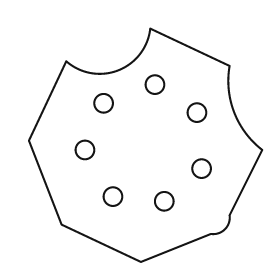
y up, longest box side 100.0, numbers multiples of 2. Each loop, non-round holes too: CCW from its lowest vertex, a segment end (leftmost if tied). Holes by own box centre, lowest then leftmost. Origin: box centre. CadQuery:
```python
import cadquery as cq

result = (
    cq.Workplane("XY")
    .moveTo(-2.0, -50.0)
    .lineTo(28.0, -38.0)
    .threePointArc((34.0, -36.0), (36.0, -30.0))
    .lineTo(50.0, -2.0)
    .threePointArc((38.0, 14.0), (36.0, 34.0))
    .lineTo(2.0, 50.0)
    .threePointArc((-12.0, 32.0), (-34.0, 36.0))
    .lineTo(-50.0, 2.0)
    .lineTo(-36.0, -34.0)
    .close()
    .moveTo(8.0, -24.0)
    .circle(4.0)
    .moveTo(-14.0, -22.0)
    .circle(4.0)
    .moveTo(24.0, -10.0)
    .circle(4.0)
    .moveTo(-26.0, -2.0)
    .circle(4.0)
    .moveTo(22.0, 14.0)
    .circle(4.0)
    .moveTo(-18.0, 18.0)
    .circle(4.0)
    .moveTo(4.0, 26.0)
    .circle(4.0)
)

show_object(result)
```